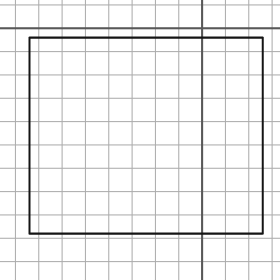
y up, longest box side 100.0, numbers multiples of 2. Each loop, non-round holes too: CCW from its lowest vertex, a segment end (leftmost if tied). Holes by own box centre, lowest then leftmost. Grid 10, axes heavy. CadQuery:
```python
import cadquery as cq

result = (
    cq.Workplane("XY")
    .moveTo(-74.0, -88.0)
    .lineTo(26.0, -88.0)
    .lineTo(26.0, -4.0)
    .lineTo(-74.0, -4.0)
    .close()
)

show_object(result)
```